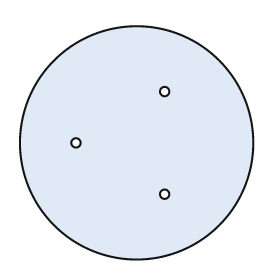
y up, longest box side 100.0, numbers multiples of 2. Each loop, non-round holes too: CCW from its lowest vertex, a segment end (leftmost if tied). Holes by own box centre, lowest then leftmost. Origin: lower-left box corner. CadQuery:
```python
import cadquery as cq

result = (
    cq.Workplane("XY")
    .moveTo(50.0, 50.0)
    .circle(50.0)
    .moveTo(62.0, 28.0)
    .circle(2.0)
    .moveTo(24.0, 50.0)
    .circle(2.0)
    .moveTo(62.0, 72.0)
    .circle(2.0)
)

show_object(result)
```